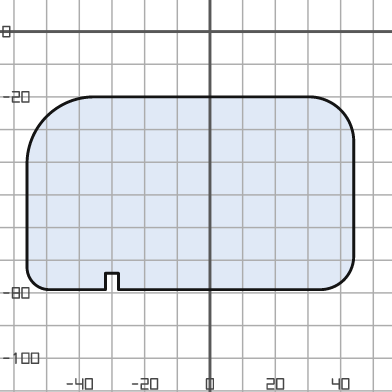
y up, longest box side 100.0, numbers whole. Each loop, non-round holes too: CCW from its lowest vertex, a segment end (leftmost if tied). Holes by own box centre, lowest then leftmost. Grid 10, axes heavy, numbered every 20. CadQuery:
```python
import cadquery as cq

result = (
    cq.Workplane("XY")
    .moveTo(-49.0, -79.0)
    .lineTo(-32.0, -79.0)
    .lineTo(-32.0, -74.0)
    .lineTo(-28.0, -74.0)
    .lineTo(-28.0, -79.0)
    .lineTo(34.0, -79.0)
    .threePointArc((41.0, -76.0), (44.0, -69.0))
    .lineTo(44.0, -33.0)
    .threePointArc((40.0, -24.0), (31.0, -20.0))
    .lineTo(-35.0, -20.0)
    .threePointArc((-50.0, -26.0), (-56.0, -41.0))
    .lineTo(-56.0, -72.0)
    .threePointArc((-54.0, -77.0), (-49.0, -79.0))
    .close()
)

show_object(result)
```